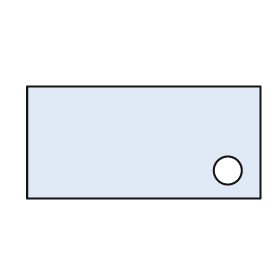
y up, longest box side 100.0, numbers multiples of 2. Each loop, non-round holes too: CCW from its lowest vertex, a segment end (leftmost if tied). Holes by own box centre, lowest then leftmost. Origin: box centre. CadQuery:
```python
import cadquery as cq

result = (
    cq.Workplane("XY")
    .moveTo(-50.0, -24.0)
    .lineTo(50.0, -24.0)
    .lineTo(50.0, 24.0)
    .lineTo(-50.0, 24.0)
    .close()
    .moveTo(36.0, -12.0)
    .circle(6.0)
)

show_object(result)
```